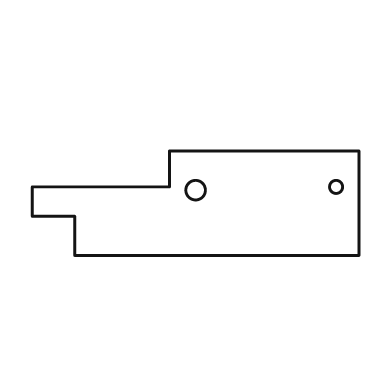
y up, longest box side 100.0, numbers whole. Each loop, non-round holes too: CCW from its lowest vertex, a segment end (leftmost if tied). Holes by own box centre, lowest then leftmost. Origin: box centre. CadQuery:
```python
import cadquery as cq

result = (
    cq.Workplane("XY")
    .moveTo(-37.0, -16.0)
    .lineTo(50.0, -16.0)
    .lineTo(50.0, 16.0)
    .lineTo(-8.0, 16.0)
    .lineTo(-8.0, 5.0)
    .lineTo(-50.0, 5.0)
    .lineTo(-50.0, -4.0)
    .lineTo(-37.0, -4.0)
    .close()
    .moveTo(0.0, 4.0)
    .circle(3.0)
    .moveTo(43.0, 5.0)
    .circle(2.0)
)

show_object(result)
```